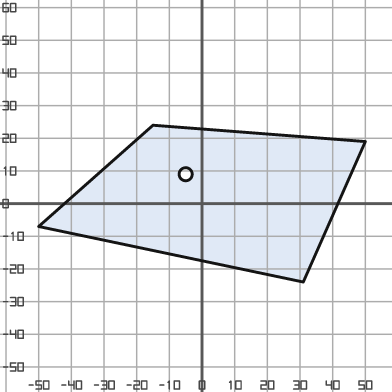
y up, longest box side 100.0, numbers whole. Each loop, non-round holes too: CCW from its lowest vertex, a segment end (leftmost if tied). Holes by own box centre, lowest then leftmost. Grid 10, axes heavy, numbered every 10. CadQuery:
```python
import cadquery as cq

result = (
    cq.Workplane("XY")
    .moveTo(31.0, -24.0)
    .lineTo(50.0, 19.0)
    .lineTo(-15.0, 24.0)
    .lineTo(-50.0, -7.0)
    .close()
    .moveTo(-5.0, 9.0)
    .circle(2.0)
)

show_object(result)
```